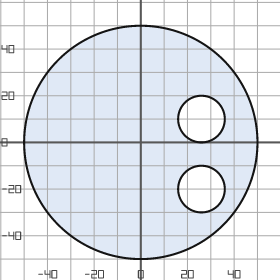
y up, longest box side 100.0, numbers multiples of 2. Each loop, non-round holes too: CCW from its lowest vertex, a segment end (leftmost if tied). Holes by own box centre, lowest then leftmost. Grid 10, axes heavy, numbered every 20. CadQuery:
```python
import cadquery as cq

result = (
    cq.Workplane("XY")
    .moveTo(0.0, 0.0)
    .circle(50.0)
    .moveTo(26.0, -20.0)
    .circle(10.0)
    .moveTo(26.0, 10.0)
    .circle(10.0)
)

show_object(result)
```